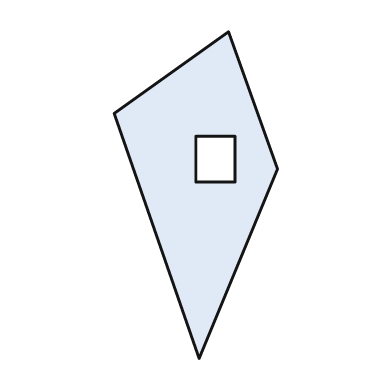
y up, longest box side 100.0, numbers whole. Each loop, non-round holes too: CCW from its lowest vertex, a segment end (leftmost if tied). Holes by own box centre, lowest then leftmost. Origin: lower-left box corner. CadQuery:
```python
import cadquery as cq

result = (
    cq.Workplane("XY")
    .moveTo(26.0, 0.0)
    .lineTo(50.0, 58.0)
    .lineTo(35.0, 100.0)
    .lineTo(0.0, 75.0)
    .close()
    .moveTo(25.0, 54.0)
    .lineTo(37.0, 54.0)
    .lineTo(37.0, 68.0)
    .lineTo(25.0, 68.0)
    .close()
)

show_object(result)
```